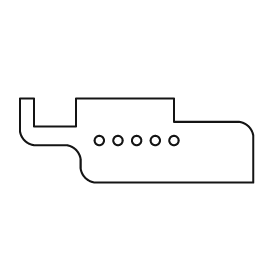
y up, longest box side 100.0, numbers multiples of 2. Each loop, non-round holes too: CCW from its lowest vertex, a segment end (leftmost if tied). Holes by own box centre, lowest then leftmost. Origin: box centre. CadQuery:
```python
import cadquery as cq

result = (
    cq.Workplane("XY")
    .moveTo(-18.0, -18.0)
    .lineTo(50.0, -18.0)
    .lineTo(50.0, 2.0)
    .threePointArc((48.0, 6.0), (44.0, 8.0))
    .lineTo(16.0, 8.0)
    .lineTo(16.0, 18.0)
    .lineTo(-26.0, 18.0)
    .lineTo(-26.0, 6.0)
    .lineTo(-44.0, 6.0)
    .lineTo(-44.0, 18.0)
    .lineTo(-50.0, 18.0)
    .lineTo(-50.0, 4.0)
    .threePointArc((-48.0, 0.0), (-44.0, -2.0))
    .lineTo(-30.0, -2.0)
    .threePointArc((-26.0, -4.0), (-24.0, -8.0))
    .lineTo(-24.0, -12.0)
    .threePointArc((-22.0, -16.0), (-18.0, -18.0))
    .close()
    .moveTo(-16.0, 0.0)
    .circle(2.0)
    .moveTo(-8.0, 0.0)
    .circle(2.0)
    .moveTo(0.0, 0.0)
    .circle(2.0)
    .moveTo(8.0, 0.0)
    .circle(2.0)
    .moveTo(16.0, 0.0)
    .circle(2.0)
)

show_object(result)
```